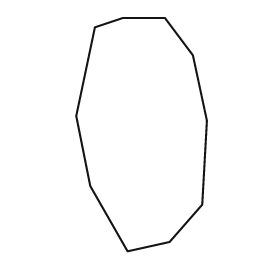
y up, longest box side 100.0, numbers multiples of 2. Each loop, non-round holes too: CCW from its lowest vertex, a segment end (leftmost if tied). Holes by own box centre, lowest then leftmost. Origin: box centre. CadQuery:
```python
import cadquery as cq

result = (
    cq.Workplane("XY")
    .moveTo(-6.0, -50.0)
    .lineTo(12.0, -46.0)
    .lineTo(26.0, -30.0)
    .lineTo(28.0, 6.0)
    .lineTo(22.0, 34.0)
    .lineTo(10.0, 50.0)
    .lineTo(-8.0, 50.0)
    .lineTo(-20.0, 46.0)
    .lineTo(-28.0, 8.0)
    .lineTo(-22.0, -22.0)
    .close()
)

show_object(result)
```